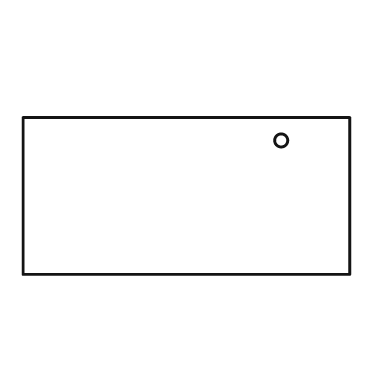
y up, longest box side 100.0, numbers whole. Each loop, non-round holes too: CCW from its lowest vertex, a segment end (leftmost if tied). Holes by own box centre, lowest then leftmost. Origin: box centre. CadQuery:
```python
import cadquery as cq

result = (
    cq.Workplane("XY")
    .moveTo(-50.0, -24.0)
    .lineTo(50.0, -24.0)
    .lineTo(50.0, 24.0)
    .lineTo(-50.0, 24.0)
    .close()
    .moveTo(29.0, 17.0)
    .circle(2.0)
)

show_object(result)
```